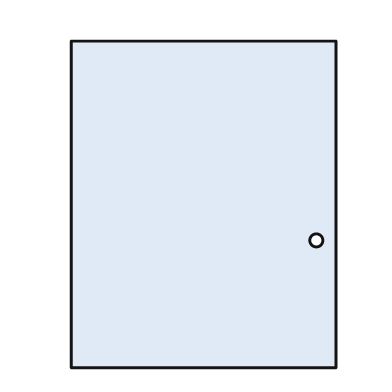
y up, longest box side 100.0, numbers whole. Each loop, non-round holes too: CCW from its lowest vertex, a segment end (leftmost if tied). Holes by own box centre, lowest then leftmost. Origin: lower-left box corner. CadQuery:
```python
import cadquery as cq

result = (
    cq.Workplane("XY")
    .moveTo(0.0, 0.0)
    .lineTo(81.0, 0.0)
    .lineTo(81.0, 100.0)
    .lineTo(0.0, 100.0)
    .close()
    .moveTo(75.0, 39.0)
    .circle(2.0)
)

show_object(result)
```